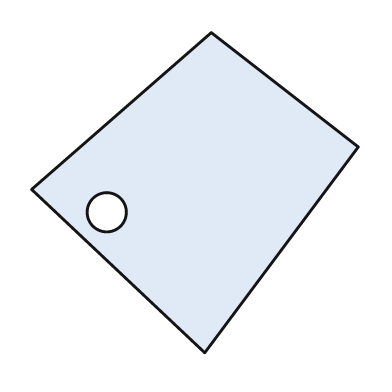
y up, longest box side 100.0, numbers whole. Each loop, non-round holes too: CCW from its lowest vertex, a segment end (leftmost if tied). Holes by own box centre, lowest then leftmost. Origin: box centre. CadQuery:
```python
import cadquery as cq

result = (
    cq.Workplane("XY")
    .moveTo(3.0, -49.0)
    .lineTo(50.0, 14.0)
    .lineTo(5.0, 49.0)
    .lineTo(-50.0, 1.0)
    .close()
    .moveTo(-27.0, -6.0)
    .circle(6.0)
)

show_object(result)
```